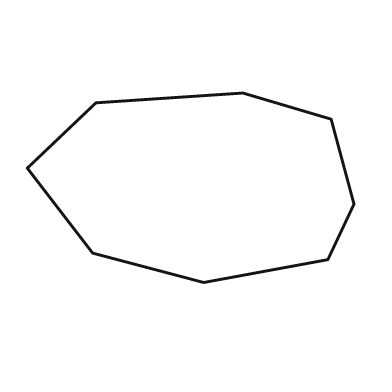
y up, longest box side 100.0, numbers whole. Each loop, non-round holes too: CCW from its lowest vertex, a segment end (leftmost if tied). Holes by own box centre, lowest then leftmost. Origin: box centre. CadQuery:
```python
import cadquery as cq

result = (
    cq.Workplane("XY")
    .moveTo(4.0, -29.0)
    .lineTo(42.0, -22.0)
    .lineTo(50.0, -5.0)
    .lineTo(43.0, 21.0)
    .lineTo(16.0, 29.0)
    .lineTo(-29.0, 26.0)
    .lineTo(-50.0, 6.0)
    .lineTo(-30.0, -20.0)
    .close()
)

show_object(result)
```